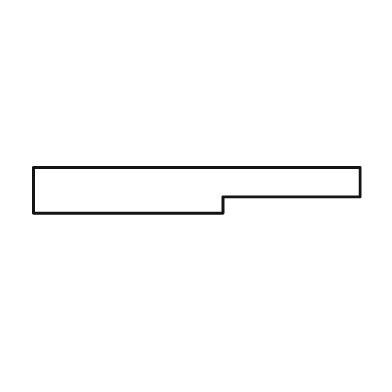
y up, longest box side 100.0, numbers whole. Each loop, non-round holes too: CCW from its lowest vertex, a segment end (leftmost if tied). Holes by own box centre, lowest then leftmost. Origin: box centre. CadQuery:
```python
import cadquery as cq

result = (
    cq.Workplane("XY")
    .moveTo(-50.0, -7.0)
    .lineTo(8.0, -7.0)
    .lineTo(8.0, -2.0)
    .lineTo(50.0, -2.0)
    .lineTo(50.0, 7.0)
    .lineTo(-50.0, 7.0)
    .close()
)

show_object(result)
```